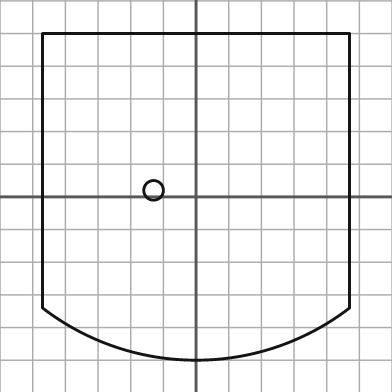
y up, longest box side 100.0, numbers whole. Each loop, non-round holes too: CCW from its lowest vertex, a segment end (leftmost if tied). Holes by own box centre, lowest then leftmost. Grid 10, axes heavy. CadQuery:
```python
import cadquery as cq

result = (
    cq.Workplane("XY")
    .moveTo(-47.0, -34.0)
    .threePointArc((0.0, -50.0), (47.0, -34.0))
    .lineTo(47.0, 50.0)
    .lineTo(-47.0, 50.0)
    .close()
    .moveTo(-13.0, 2.0)
    .circle(3.0)
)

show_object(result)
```